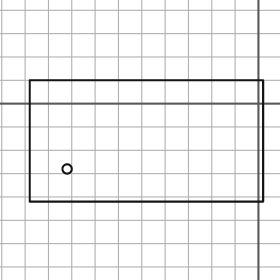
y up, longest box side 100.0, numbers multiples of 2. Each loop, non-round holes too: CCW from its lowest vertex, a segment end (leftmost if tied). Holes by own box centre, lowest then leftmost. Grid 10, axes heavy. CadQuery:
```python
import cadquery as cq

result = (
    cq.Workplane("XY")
    .moveTo(-98.0, -42.0)
    .lineTo(2.0, -42.0)
    .lineTo(2.0, 10.0)
    .lineTo(-98.0, 10.0)
    .close()
    .moveTo(-82.0, -28.0)
    .circle(2.0)
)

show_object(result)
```